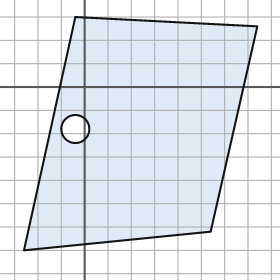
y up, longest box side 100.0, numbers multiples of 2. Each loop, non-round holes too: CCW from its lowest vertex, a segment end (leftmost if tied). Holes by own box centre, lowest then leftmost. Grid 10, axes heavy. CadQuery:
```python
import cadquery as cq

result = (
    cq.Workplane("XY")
    .moveTo(-26.0, -70.0)
    .lineTo(54.0, -62.0)
    .lineTo(74.0, 26.0)
    .lineTo(-4.0, 30.0)
    .close()
    .moveTo(-4.0, -18.0)
    .circle(6.0)
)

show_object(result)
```